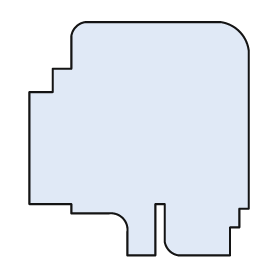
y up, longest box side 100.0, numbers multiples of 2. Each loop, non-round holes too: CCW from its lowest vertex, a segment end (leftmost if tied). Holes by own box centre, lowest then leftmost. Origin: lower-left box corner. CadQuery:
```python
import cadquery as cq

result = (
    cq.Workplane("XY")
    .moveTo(42.0, 0.0)
    .lineTo(54.0, 0.0)
    .lineTo(54.0, 22.0)
    .lineTo(58.0, 22.0)
    .lineTo(58.0, 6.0)
    .threePointArc((60.0, 2.0), (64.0, 0.0))
    .lineTo(86.0, 0.0)
    .lineTo(86.0, 12.0)
    .lineTo(90.0, 12.0)
    .lineTo(90.0, 20.0)
    .lineTo(94.0, 20.0)
    .lineTo(94.0, 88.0)
    .threePointArc((90.0, 96.0), (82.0, 100.0))
    .lineTo(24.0, 100.0)
    .threePointArc((20.0, 98.0), (18.0, 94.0))
    .lineTo(18.0, 80.0)
    .lineTo(10.0, 80.0)
    .lineTo(10.0, 70.0)
    .lineTo(0.0, 70.0)
    .lineTo(0.0, 22.0)
    .lineTo(18.0, 22.0)
    .lineTo(18.0, 18.0)
    .lineTo(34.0, 18.0)
    .threePointArc((40.0, 16.0), (42.0, 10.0))
    .close()
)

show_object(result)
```